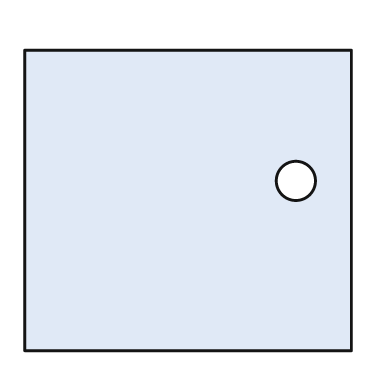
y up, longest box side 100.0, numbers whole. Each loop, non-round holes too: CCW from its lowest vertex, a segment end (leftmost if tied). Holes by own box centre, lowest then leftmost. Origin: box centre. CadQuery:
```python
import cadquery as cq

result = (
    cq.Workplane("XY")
    .moveTo(-50.0, -46.0)
    .lineTo(50.0, -46.0)
    .lineTo(50.0, 46.0)
    .lineTo(-50.0, 46.0)
    .close()
    .moveTo(33.0, 6.0)
    .circle(6.0)
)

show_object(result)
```